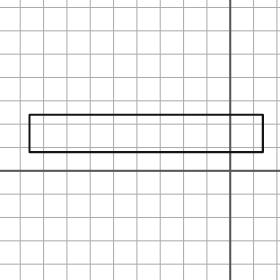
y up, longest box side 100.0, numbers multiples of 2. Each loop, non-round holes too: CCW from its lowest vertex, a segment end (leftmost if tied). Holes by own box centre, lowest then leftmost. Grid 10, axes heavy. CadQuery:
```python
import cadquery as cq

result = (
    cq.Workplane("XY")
    .moveTo(-86.0, 8.0)
    .lineTo(14.0, 8.0)
    .lineTo(14.0, 24.0)
    .lineTo(-86.0, 24.0)
    .close()
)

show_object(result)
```